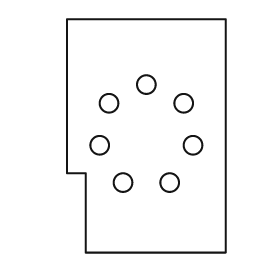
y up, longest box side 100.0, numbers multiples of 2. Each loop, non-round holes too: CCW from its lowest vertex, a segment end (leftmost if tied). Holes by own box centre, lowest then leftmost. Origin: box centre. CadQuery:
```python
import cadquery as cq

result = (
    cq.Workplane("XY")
    .moveTo(-26.0, -50.0)
    .lineTo(34.0, -50.0)
    .lineTo(34.0, 50.0)
    .lineTo(-34.0, 50.0)
    .lineTo(-34.0, -16.0)
    .lineTo(-26.0, -16.0)
    .close()
    .moveTo(-10.0, -20.0)
    .circle(4.0)
    .moveTo(10.0, -20.0)
    .circle(4.0)
    .moveTo(-20.0, -4.0)
    .circle(4.0)
    .moveTo(20.0, -4.0)
    .circle(4.0)
    .moveTo(-16.0, 14.0)
    .circle(4.0)
    .moveTo(16.0, 14.0)
    .circle(4.0)
    .moveTo(0.0, 22.0)
    .circle(4.0)
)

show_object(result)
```